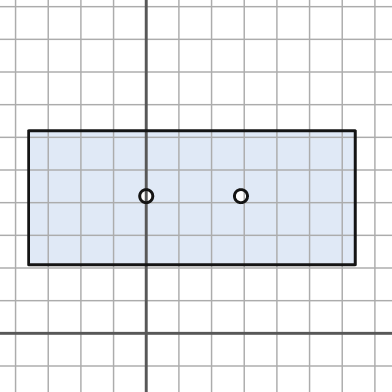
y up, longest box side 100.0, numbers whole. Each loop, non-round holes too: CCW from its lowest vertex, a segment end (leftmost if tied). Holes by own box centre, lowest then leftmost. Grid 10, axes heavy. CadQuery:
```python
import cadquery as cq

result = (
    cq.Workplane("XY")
    .moveTo(-36.0, 21.0)
    .lineTo(64.0, 21.0)
    .lineTo(64.0, 62.0)
    .lineTo(-36.0, 62.0)
    .close()
    .moveTo(0.0, 42.0)
    .circle(2.0)
    .moveTo(29.0, 42.0)
    .circle(2.0)
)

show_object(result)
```